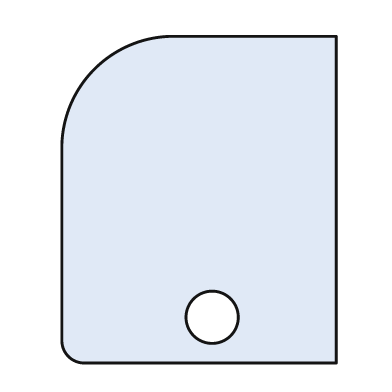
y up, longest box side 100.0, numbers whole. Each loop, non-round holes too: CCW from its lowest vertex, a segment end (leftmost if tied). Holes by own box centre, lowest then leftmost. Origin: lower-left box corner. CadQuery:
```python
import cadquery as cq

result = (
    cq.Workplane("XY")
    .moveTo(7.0, 0.0)
    .lineTo(84.0, 0.0)
    .lineTo(84.0, 100.0)
    .lineTo(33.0, 100.0)
    .threePointArc((10.0, 90.0), (0.0, 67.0))
    .lineTo(0.0, 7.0)
    .threePointArc((2.0, 2.0), (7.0, 0.0))
    .close()
    .moveTo(46.0, 14.0)
    .circle(8.0)
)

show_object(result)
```